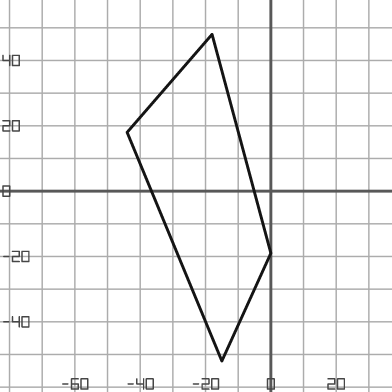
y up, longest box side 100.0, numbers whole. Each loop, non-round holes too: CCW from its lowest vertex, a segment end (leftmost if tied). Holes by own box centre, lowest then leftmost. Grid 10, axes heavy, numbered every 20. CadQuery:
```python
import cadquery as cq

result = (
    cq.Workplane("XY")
    .moveTo(-15.0, -52.0)
    .lineTo(0.0, -19.0)
    .lineTo(-18.0, 48.0)
    .lineTo(-44.0, 18.0)
    .close()
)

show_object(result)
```